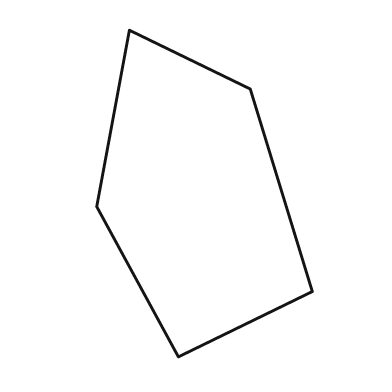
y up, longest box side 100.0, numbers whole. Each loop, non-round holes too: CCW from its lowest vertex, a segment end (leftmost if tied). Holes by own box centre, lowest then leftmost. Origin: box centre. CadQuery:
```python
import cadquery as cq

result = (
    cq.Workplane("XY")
    .moveTo(-8.0, -50.0)
    .lineTo(33.0, -30.0)
    .lineTo(14.0, 32.0)
    .lineTo(-23.0, 50.0)
    .lineTo(-33.0, -4.0)
    .close()
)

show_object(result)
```